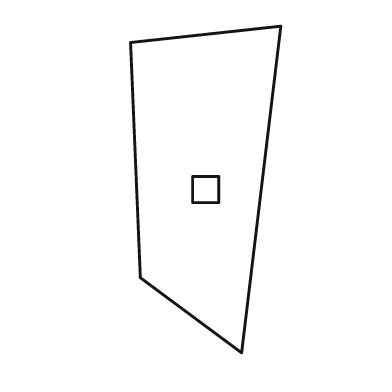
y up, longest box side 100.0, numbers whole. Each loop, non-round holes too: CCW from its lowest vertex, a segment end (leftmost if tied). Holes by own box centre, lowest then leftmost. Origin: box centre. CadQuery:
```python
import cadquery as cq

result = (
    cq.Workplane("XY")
    .moveTo(11.0, -50.0)
    .lineTo(23.0, 50.0)
    .lineTo(-23.0, 45.0)
    .lineTo(-20.0, -27.0)
    .close()
    .moveTo(-4.0, -4.0)
    .lineTo(4.0, -4.0)
    .lineTo(4.0, 4.0)
    .lineTo(-4.0, 4.0)
    .close()
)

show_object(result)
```